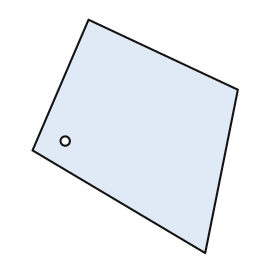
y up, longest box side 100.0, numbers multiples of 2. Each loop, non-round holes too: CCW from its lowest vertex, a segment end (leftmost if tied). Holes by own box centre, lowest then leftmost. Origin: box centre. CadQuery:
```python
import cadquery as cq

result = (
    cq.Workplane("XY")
    .moveTo(30.0, -50.0)
    .lineTo(44.0, 20.0)
    .lineTo(-20.0, 50.0)
    .lineTo(-44.0, -6.0)
    .close()
    .moveTo(-30.0, -2.0)
    .circle(2.0)
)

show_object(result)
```